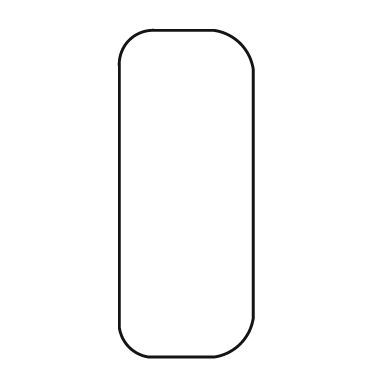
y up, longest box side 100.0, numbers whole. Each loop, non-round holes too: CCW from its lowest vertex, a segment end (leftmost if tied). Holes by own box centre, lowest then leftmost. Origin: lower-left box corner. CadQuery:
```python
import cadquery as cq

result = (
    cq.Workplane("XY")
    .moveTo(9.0, 0.0)
    .lineTo(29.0, 0.0)
    .threePointArc((37.0, 4.0), (41.0, 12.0))
    .lineTo(41.0, 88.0)
    .threePointArc((37.0, 96.0), (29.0, 100.0))
    .lineTo(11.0, 100.0)
    .threePointArc((3.0, 97.0), (0.0, 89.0))
    .lineTo(0.0, 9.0)
    .threePointArc((3.0, 3.0), (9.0, 0.0))
    .close()
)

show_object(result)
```